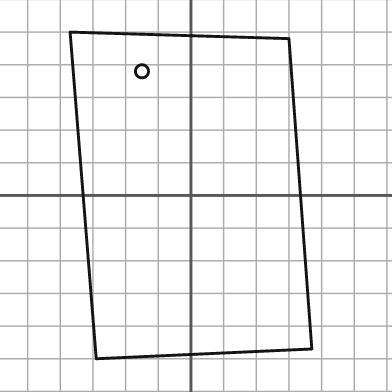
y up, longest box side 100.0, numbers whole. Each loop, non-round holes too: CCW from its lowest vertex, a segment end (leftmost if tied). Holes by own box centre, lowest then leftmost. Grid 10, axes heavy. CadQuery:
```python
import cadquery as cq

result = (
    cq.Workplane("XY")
    .moveTo(-29.0, -50.0)
    .lineTo(37.0, -47.0)
    .lineTo(30.0, 48.0)
    .lineTo(-37.0, 50.0)
    .close()
    .moveTo(-15.0, 38.0)
    .circle(2.0)
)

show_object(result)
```